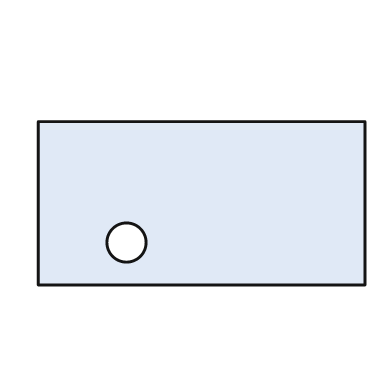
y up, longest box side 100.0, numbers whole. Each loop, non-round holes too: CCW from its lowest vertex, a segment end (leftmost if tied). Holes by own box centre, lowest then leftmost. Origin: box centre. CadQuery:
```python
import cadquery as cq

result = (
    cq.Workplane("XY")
    .moveTo(-50.0, -25.0)
    .lineTo(50.0, -25.0)
    .lineTo(50.0, 25.0)
    .lineTo(-50.0, 25.0)
    .close()
    .moveTo(-23.0, -12.0)
    .circle(6.0)
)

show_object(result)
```